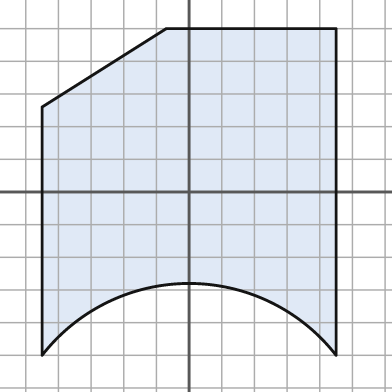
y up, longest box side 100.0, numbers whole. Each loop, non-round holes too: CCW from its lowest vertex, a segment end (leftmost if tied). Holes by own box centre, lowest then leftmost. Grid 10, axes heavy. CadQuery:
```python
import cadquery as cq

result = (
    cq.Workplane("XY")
    .moveTo(-45.0, -50.0)
    .threePointArc((0.0, -28.0), (45.0, -50.0))
    .lineTo(45.0, 50.0)
    .lineTo(-7.0, 50.0)
    .lineTo(-45.0, 26.0)
    .close()
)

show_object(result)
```